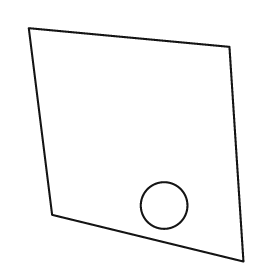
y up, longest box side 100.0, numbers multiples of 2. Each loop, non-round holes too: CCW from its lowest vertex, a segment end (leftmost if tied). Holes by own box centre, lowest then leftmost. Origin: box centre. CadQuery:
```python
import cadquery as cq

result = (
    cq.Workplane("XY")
    .moveTo(46.0, -50.0)
    .lineTo(40.0, 42.0)
    .lineTo(-46.0, 50.0)
    .lineTo(-36.0, -30.0)
    .close()
    .moveTo(12.0, -26.0)
    .circle(10.0)
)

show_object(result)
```